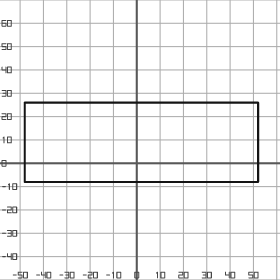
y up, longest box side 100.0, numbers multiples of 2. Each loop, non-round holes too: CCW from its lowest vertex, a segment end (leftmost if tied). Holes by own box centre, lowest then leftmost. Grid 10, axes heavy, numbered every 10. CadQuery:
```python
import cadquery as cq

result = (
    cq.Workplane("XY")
    .moveTo(-48.0, -8.0)
    .lineTo(52.0, -8.0)
    .lineTo(52.0, 26.0)
    .lineTo(-48.0, 26.0)
    .close()
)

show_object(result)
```